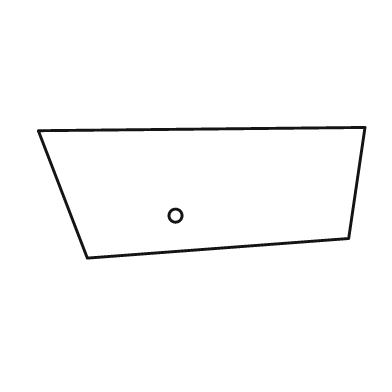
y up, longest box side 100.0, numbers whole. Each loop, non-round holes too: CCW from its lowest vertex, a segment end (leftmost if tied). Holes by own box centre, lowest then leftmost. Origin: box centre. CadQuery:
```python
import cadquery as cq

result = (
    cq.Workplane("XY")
    .moveTo(-35.0, -20.0)
    .lineTo(45.0, -14.0)
    .lineTo(50.0, 20.0)
    .lineTo(-50.0, 19.0)
    .close()
    .moveTo(-8.0, -7.0)
    .circle(2.0)
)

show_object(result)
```